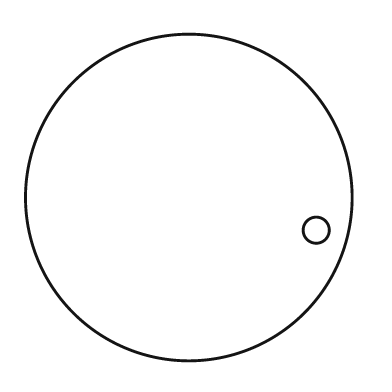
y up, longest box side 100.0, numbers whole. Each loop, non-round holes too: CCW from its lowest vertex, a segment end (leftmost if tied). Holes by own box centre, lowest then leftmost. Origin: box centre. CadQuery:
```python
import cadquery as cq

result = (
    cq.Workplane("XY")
    .moveTo(0.0, 0.0)
    .circle(50.0)
    .moveTo(39.0, -10.0)
    .circle(4.0)
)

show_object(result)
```